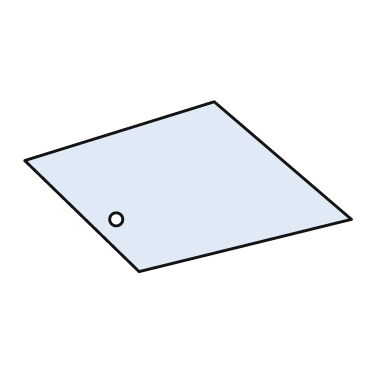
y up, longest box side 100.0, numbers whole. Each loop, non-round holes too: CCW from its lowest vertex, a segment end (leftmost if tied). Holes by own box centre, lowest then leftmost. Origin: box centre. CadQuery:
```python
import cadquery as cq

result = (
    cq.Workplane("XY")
    .moveTo(-15.0, -26.0)
    .lineTo(50.0, -10.0)
    .lineTo(8.0, 26.0)
    .lineTo(-50.0, 8.0)
    .close()
    .moveTo(-22.0, -10.0)
    .circle(2.0)
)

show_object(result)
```